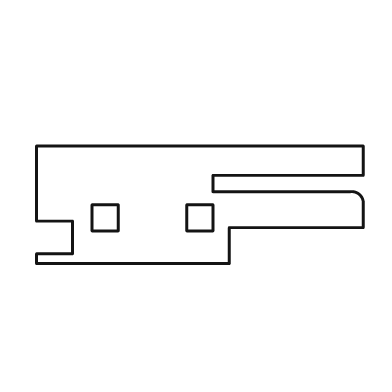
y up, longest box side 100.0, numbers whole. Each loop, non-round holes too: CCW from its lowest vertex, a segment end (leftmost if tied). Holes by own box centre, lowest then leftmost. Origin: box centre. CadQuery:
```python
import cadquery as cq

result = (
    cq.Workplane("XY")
    .moveTo(-50.0, -18.0)
    .lineTo(9.0, -18.0)
    .lineTo(9.0, -7.0)
    .lineTo(50.0, -7.0)
    .lineTo(50.0, 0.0)
    .threePointArc((49.0, 3.0), (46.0, 4.0))
    .lineTo(4.0, 4.0)
    .lineTo(4.0, 9.0)
    .lineTo(50.0, 9.0)
    .lineTo(50.0, 18.0)
    .lineTo(-50.0, 18.0)
    .lineTo(-50.0, -5.0)
    .lineTo(-39.0, -5.0)
    .lineTo(-39.0, -15.0)
    .lineTo(-50.0, -15.0)
    .close()
    .moveTo(-33.0, -8.0)
    .lineTo(-25.0, -8.0)
    .lineTo(-25.0, 0.0)
    .lineTo(-33.0, 0.0)
    .close()
    .moveTo(-4.0, -8.0)
    .lineTo(4.0, -8.0)
    .lineTo(4.0, 0.0)
    .lineTo(-4.0, 0.0)
    .close()
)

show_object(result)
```